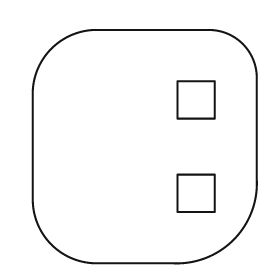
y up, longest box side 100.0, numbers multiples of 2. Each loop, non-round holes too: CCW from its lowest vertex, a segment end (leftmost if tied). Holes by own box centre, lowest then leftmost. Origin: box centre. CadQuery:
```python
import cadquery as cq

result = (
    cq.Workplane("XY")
    .moveTo(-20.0, -50.0)
    .lineTo(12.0, -50.0)
    .threePointArc((38.0, -40.0), (48.0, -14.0))
    .lineTo(48.0, 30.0)
    .threePointArc((42.0, 44.0), (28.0, 50.0))
    .lineTo(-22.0, 50.0)
    .threePointArc((-40.0, 42.0), (-48.0, 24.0))
    .lineTo(-48.0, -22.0)
    .threePointArc((-40.0, -42.0), (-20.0, -50.0))
    .close()
    .moveTo(14.0, -28.0)
    .lineTo(30.0, -28.0)
    .lineTo(30.0, -12.0)
    .lineTo(14.0, -12.0)
    .close()
    .moveTo(14.0, 12.0)
    .lineTo(30.0, 12.0)
    .lineTo(30.0, 28.0)
    .lineTo(14.0, 28.0)
    .close()
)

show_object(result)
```